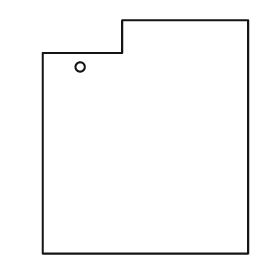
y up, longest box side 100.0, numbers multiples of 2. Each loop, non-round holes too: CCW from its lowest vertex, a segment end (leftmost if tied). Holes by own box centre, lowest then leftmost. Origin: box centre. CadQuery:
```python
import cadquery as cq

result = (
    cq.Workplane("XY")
    .moveTo(-44.0, -50.0)
    .lineTo(44.0, -50.0)
    .lineTo(44.0, 50.0)
    .lineTo(-10.0, 50.0)
    .lineTo(-10.0, 36.0)
    .lineTo(-44.0, 36.0)
    .close()
    .moveTo(-28.0, 30.0)
    .circle(2.0)
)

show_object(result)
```